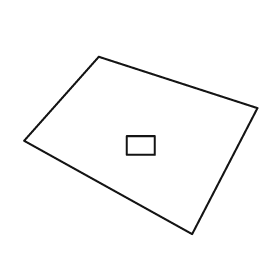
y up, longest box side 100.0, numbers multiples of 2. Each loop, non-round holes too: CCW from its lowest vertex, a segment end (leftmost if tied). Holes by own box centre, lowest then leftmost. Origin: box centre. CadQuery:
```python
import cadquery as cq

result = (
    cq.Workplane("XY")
    .moveTo(22.0, -38.0)
    .lineTo(50.0, 16.0)
    .lineTo(-18.0, 38.0)
    .lineTo(-50.0, 2.0)
    .close()
    .moveTo(-6.0, -4.0)
    .lineTo(6.0, -4.0)
    .lineTo(6.0, 4.0)
    .lineTo(-6.0, 4.0)
    .close()
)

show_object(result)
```